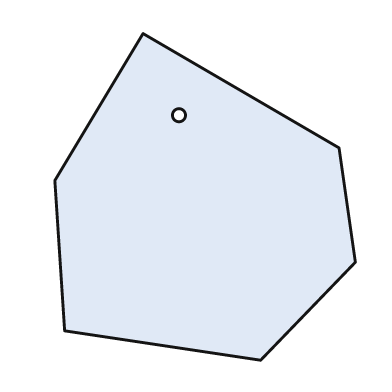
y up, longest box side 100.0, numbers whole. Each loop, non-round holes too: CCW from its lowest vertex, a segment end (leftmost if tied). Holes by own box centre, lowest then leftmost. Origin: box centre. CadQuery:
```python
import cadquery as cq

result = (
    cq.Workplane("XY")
    .moveTo(17.0, -50.0)
    .lineTo(46.0, -20.0)
    .lineTo(41.0, 15.0)
    .lineTo(-19.0, 50.0)
    .lineTo(-46.0, 5.0)
    .lineTo(-43.0, -41.0)
    .close()
    .moveTo(-8.0, 25.0)
    .circle(2.0)
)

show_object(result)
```